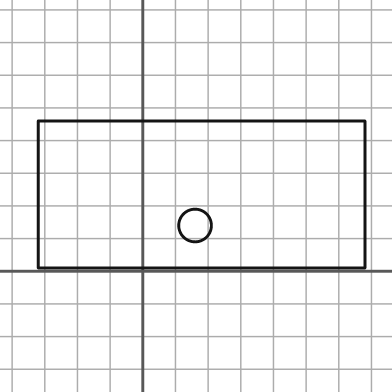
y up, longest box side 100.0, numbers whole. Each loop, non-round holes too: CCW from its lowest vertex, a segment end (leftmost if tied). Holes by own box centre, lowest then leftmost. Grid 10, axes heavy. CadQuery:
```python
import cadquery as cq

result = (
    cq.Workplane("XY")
    .moveTo(-32.0, 1.0)
    .lineTo(68.0, 1.0)
    .lineTo(68.0, 46.0)
    .lineTo(-32.0, 46.0)
    .close()
    .moveTo(16.0, 14.0)
    .circle(5.0)
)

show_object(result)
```